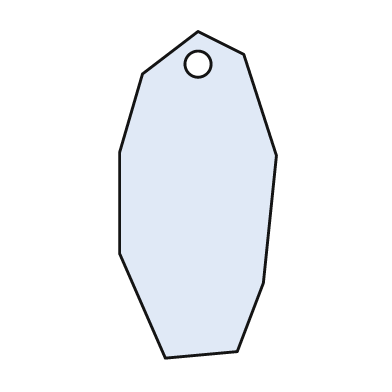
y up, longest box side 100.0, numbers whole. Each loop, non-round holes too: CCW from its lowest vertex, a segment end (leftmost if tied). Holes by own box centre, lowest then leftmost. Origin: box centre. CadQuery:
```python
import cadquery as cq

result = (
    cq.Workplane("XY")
    .moveTo(-10.0, -50.0)
    .lineTo(12.0, -48.0)
    .lineTo(20.0, -27.0)
    .lineTo(24.0, 12.0)
    .lineTo(14.0, 43.0)
    .lineTo(0.0, 50.0)
    .lineTo(-17.0, 37.0)
    .lineTo(-24.0, 13.0)
    .lineTo(-24.0, -18.0)
    .close()
    .moveTo(0.0, 40.0)
    .circle(4.0)
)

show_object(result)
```